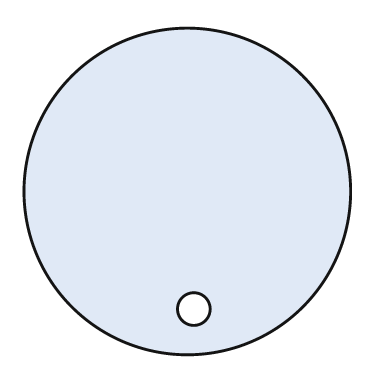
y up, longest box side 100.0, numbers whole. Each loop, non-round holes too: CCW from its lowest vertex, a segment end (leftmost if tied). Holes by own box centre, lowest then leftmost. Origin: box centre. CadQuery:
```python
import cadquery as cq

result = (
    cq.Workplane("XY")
    .moveTo(0.0, 0.0)
    .circle(50.0)
    .moveTo(2.0, -36.0)
    .circle(5.0)
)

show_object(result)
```